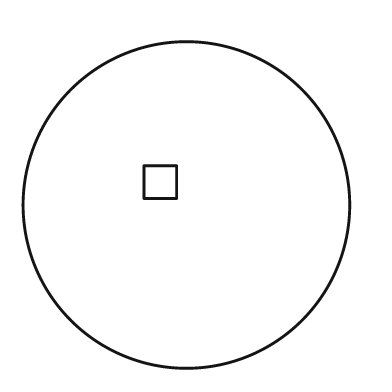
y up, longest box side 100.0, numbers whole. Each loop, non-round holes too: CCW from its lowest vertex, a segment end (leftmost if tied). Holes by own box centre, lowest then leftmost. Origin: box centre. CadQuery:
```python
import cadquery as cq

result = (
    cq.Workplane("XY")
    .moveTo(0.0, 0.0)
    .circle(50.0)
    .moveTo(-13.0, 2.0)
    .lineTo(-3.0, 2.0)
    .lineTo(-3.0, 12.0)
    .lineTo(-13.0, 12.0)
    .close()
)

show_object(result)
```